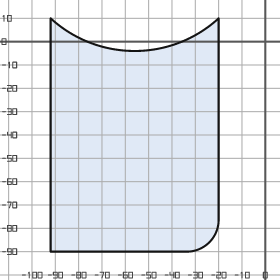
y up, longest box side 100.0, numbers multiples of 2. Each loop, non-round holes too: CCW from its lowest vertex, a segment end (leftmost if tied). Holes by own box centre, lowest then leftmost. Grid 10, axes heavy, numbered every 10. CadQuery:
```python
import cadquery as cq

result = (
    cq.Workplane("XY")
    .moveTo(-92.0, -90.0)
    .lineTo(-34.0, -90.0)
    .threePointArc((-24.0, -86.0), (-20.0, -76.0))
    .lineTo(-20.0, 10.0)
    .threePointArc((-56.0, -4.0), (-92.0, 10.0))
    .close()
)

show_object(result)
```